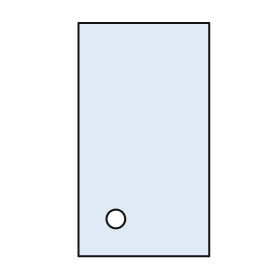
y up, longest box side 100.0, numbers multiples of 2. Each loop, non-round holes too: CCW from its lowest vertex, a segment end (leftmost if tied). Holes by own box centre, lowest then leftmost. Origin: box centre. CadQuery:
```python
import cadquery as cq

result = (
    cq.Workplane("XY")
    .moveTo(-28.0, -50.0)
    .lineTo(28.0, -50.0)
    .lineTo(28.0, 50.0)
    .lineTo(-28.0, 50.0)
    .close()
    .moveTo(-12.0, -34.0)
    .circle(4.0)
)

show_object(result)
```